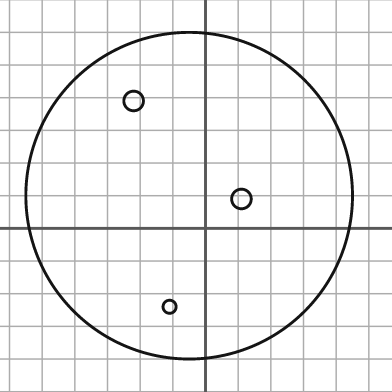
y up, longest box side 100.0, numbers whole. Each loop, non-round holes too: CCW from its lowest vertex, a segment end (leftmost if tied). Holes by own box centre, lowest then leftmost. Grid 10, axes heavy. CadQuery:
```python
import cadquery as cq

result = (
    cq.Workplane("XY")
    .moveTo(-5.0, 10.0)
    .circle(50.0)
    .moveTo(-11.0, -24.0)
    .circle(2.0)
    .moveTo(11.0, 9.0)
    .circle(3.0)
    .moveTo(-22.0, 39.0)
    .circle(3.0)
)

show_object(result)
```